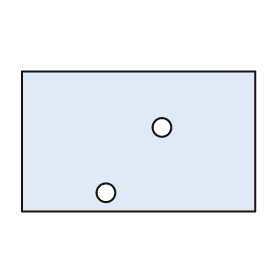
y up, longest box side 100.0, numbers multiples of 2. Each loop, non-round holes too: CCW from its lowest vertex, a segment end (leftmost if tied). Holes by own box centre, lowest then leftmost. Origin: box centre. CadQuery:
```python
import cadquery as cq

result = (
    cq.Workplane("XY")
    .moveTo(-50.0, -30.0)
    .lineTo(50.0, -30.0)
    .lineTo(50.0, 30.0)
    .lineTo(-50.0, 30.0)
    .close()
    .moveTo(-14.0, -22.0)
    .circle(4.0)
    .moveTo(10.0, 6.0)
    .circle(4.0)
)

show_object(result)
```